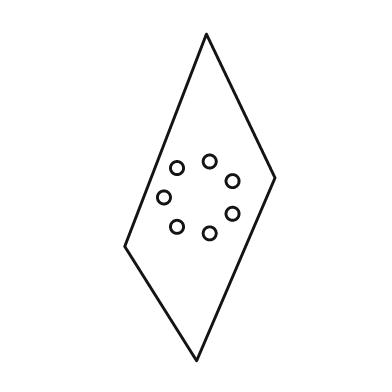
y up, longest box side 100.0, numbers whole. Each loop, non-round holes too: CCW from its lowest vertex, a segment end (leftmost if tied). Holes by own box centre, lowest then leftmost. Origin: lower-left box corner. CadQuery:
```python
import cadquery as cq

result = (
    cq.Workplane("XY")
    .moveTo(22.0, 0.0)
    .lineTo(46.0, 56.0)
    .lineTo(25.0, 100.0)
    .lineTo(0.0, 35.0)
    .close()
    .moveTo(26.0, 39.0)
    .circle(2.0)
    .moveTo(16.0, 41.0)
    .circle(2.0)
    .moveTo(33.0, 45.0)
    .circle(2.0)
    .moveTo(12.0, 50.0)
    .circle(2.0)
    .moveTo(33.0, 55.0)
    .circle(2.0)
    .moveTo(16.0, 59.0)
    .circle(2.0)
    .moveTo(26.0, 61.0)
    .circle(2.0)
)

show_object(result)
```